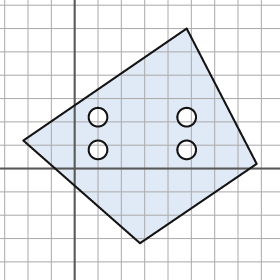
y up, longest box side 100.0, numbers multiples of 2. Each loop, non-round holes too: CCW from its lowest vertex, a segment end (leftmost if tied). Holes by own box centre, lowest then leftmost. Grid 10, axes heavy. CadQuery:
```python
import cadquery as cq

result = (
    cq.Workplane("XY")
    .moveTo(28.0, -32.0)
    .lineTo(78.0, 2.0)
    .lineTo(48.0, 60.0)
    .lineTo(-22.0, 12.0)
    .close()
    .moveTo(10.0, 8.0)
    .circle(4.0)
    .moveTo(48.0, 8.0)
    .circle(4.0)
    .moveTo(10.0, 22.0)
    .circle(4.0)
    .moveTo(48.0, 22.0)
    .circle(4.0)
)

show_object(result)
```